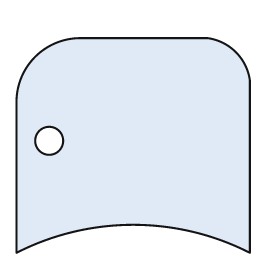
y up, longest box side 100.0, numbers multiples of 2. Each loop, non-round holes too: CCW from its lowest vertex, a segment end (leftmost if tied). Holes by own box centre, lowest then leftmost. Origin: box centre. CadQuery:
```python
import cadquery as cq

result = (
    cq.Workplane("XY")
    .moveTo(-50.0, -46.0)
    .threePointArc((0.0, -34.0), (50.0, -46.0))
    .lineTo(50.0, 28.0)
    .threePointArc((44.0, 40.0), (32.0, 46.0))
    .lineTo(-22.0, 46.0)
    .threePointArc((-42.0, 38.0), (-50.0, 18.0))
    .close()
    .moveTo(-36.0, 2.0)
    .circle(6.0)
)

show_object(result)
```